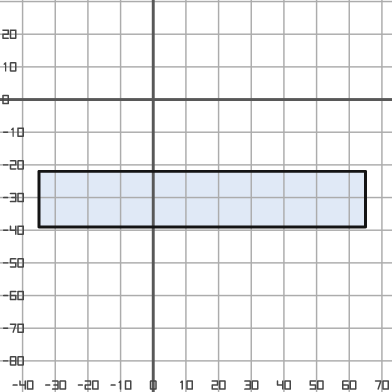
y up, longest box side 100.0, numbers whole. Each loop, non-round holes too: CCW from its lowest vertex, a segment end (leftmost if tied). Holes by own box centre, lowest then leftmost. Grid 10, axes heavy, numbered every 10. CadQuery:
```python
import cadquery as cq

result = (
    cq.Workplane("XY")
    .moveTo(-35.0, -39.0)
    .lineTo(65.0, -39.0)
    .lineTo(65.0, -22.0)
    .lineTo(-35.0, -22.0)
    .close()
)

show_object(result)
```